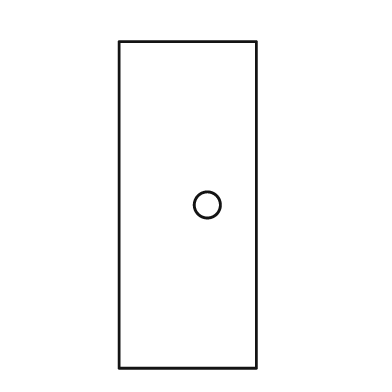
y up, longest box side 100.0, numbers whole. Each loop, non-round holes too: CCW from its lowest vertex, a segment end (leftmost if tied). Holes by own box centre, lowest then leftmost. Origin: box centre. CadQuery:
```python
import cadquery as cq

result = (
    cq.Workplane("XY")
    .moveTo(-21.0, -50.0)
    .lineTo(21.0, -50.0)
    .lineTo(21.0, 50.0)
    .lineTo(-21.0, 50.0)
    .close()
    .moveTo(6.0, 0.0)
    .circle(4.0)
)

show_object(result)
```